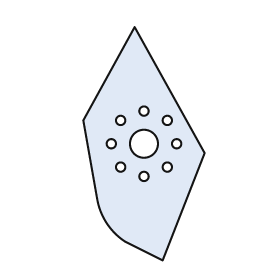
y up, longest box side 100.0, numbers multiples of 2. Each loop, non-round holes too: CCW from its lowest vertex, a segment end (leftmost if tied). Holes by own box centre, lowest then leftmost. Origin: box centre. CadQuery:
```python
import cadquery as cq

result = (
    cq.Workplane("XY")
    .moveTo(8.0, -50.0)
    .lineTo(26.0, -4.0)
    .lineTo(-4.0, 50.0)
    .lineTo(-26.0, 10.0)
    .lineTo(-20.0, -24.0)
    .threePointArc((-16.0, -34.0), (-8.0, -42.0))
    .close()
    .moveTo(0.0, -14.0)
    .circle(2.0)
    .moveTo(-10.0, -10.0)
    .circle(2.0)
    .moveTo(10.0, -10.0)
    .circle(2.0)
    .moveTo(-14.0, 0.0)
    .circle(2.0)
    .moveTo(0.0, 0.0)
    .circle(6.0)
    .moveTo(14.0, 0.0)
    .circle(2.0)
    .moveTo(-10.0, 10.0)
    .circle(2.0)
    .moveTo(10.0, 10.0)
    .circle(2.0)
    .moveTo(0.0, 14.0)
    .circle(2.0)
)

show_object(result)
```